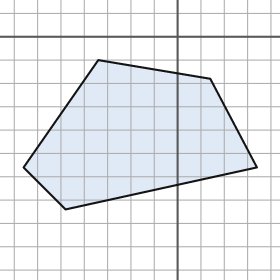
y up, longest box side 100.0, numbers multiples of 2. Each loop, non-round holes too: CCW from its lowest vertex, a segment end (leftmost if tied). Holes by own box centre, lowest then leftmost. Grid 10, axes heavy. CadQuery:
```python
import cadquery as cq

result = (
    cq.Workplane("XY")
    .moveTo(-48.0, -74.0)
    .lineTo(34.0, -56.0)
    .lineTo(14.0, -18.0)
    .lineTo(-34.0, -10.0)
    .lineTo(-66.0, -56.0)
    .close()
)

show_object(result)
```